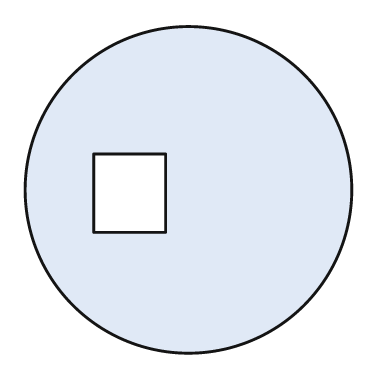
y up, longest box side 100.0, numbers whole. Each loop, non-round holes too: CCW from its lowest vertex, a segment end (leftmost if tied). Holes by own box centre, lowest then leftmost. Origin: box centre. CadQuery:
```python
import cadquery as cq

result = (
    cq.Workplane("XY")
    .moveTo(0.0, 0.0)
    .circle(50.0)
    .moveTo(-29.0, -13.0)
    .lineTo(-7.0, -13.0)
    .lineTo(-7.0, 11.0)
    .lineTo(-29.0, 11.0)
    .close()
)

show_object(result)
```